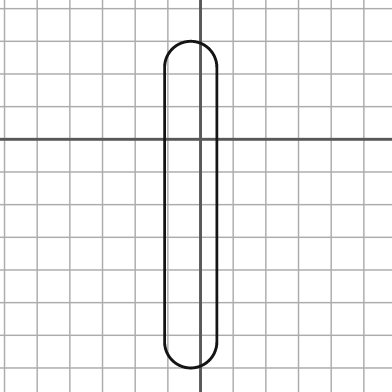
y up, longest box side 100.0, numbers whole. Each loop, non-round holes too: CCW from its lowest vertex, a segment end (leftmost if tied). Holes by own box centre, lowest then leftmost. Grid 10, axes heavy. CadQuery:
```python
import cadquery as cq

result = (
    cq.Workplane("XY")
    .moveTo(-11.0, -62.0)
    .threePointArc((-3.0, -70.0), (5.0, -62.0))
    .lineTo(5.0, 22.0)
    .threePointArc((-3.0, 30.0), (-11.0, 22.0))
    .close()
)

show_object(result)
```